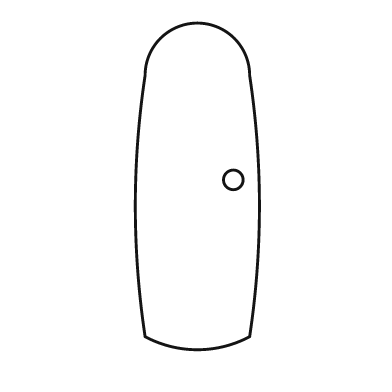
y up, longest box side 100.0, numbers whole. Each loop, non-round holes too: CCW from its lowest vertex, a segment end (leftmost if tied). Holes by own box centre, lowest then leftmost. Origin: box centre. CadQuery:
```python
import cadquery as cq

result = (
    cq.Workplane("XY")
    .moveTo(-16.0, -46.0)
    .threePointArc((0.0, -50.0), (16.0, -46.0))
    .threePointArc((19.0, -6.0), (16.0, 34.0))
    .threePointArc((0.0, 50.0), (-16.0, 34.0))
    .threePointArc((-19.0, -6.0), (-16.0, -46.0))
    .close()
    .moveTo(11.0, 2.0)
    .circle(3.0)
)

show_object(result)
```